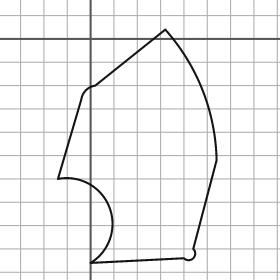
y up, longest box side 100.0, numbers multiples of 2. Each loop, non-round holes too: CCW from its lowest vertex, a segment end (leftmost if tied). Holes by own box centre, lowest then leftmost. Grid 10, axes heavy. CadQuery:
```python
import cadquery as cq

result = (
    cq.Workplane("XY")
    .moveTo(0.0, -96.0)
    .lineTo(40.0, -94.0)
    .threePointArc((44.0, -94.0), (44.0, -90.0))
    .lineTo(54.0, -52.0)
    .threePointArc((48.0, -22.0), (32.0, 4.0))
    .lineTo(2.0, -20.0)
    .threePointArc((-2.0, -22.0), (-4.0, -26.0))
    .lineTo(-14.0, -60.0)
    .threePointArc((8.0, -72.0), (0.0, -96.0))
    .close()
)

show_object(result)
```